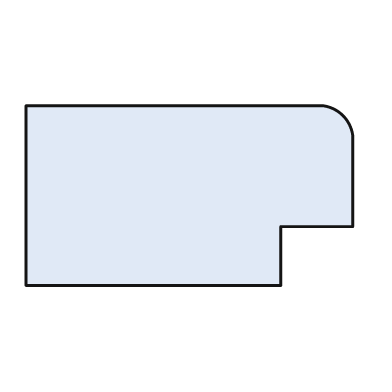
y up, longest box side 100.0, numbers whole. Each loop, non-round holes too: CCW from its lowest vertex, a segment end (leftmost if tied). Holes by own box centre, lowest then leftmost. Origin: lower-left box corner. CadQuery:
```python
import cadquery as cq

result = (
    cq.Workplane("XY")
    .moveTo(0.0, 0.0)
    .lineTo(78.0, 0.0)
    .lineTo(78.0, 18.0)
    .lineTo(100.0, 18.0)
    .lineTo(100.0, 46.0)
    .threePointArc((97.0, 52.0), (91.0, 55.0))
    .lineTo(0.0, 55.0)
    .close()
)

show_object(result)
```